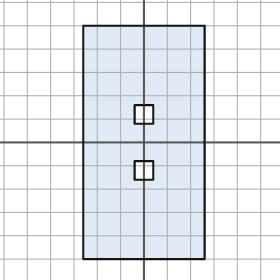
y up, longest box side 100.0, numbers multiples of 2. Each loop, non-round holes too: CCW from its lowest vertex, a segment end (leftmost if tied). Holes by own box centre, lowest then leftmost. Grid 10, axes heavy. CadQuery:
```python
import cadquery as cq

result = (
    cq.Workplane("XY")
    .moveTo(-26.0, -50.0)
    .lineTo(26.0, -50.0)
    .lineTo(26.0, 50.0)
    .lineTo(-26.0, 50.0)
    .close()
    .moveTo(-4.0, -16.0)
    .lineTo(4.0, -16.0)
    .lineTo(4.0, -8.0)
    .lineTo(-4.0, -8.0)
    .close()
    .moveTo(-4.0, 8.0)
    .lineTo(4.0, 8.0)
    .lineTo(4.0, 16.0)
    .lineTo(-4.0, 16.0)
    .close()
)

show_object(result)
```